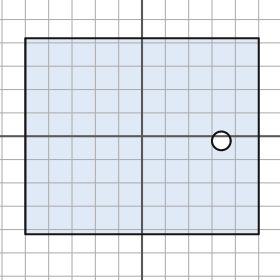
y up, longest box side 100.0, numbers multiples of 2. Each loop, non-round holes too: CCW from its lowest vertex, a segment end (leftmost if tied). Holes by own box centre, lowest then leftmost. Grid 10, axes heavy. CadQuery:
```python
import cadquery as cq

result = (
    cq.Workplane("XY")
    .moveTo(-50.0, -42.0)
    .lineTo(50.0, -42.0)
    .lineTo(50.0, 42.0)
    .lineTo(-50.0, 42.0)
    .close()
    .moveTo(34.0, -2.0)
    .circle(4.0)
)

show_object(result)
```